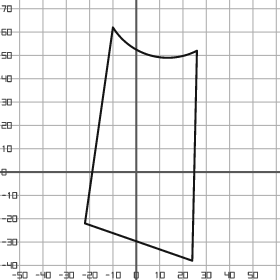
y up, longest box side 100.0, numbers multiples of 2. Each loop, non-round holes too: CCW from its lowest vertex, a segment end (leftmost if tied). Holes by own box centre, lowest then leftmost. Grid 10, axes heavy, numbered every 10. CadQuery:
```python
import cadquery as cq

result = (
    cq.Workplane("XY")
    .moveTo(24.0, -38.0)
    .lineTo(26.0, 52.0)
    .threePointArc((6.0, 50.0), (-10.0, 62.0))
    .lineTo(-22.0, -22.0)
    .close()
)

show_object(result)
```